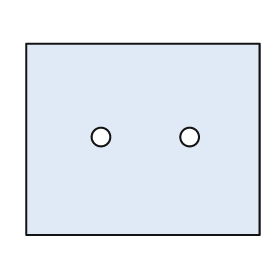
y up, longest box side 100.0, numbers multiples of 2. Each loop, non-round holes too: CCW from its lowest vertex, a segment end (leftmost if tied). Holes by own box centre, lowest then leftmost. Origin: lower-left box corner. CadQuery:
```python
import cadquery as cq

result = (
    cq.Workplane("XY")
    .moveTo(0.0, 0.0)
    .lineTo(100.0, 0.0)
    .lineTo(100.0, 82.0)
    .lineTo(0.0, 82.0)
    .close()
    .moveTo(32.0, 42.0)
    .circle(4.0)
    .moveTo(70.0, 42.0)
    .circle(4.0)
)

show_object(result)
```